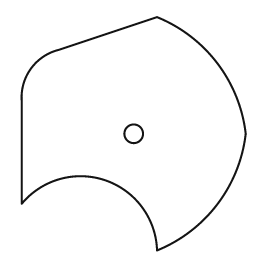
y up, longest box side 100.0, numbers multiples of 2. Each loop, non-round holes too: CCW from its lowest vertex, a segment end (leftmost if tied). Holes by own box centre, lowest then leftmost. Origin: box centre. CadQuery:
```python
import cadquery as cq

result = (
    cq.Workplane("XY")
    .moveTo(10.0, -50.0)
    .threePointArc((36.0, -30.0), (48.0, 0.0))
    .threePointArc((36.0, 30.0), (10.0, 50.0))
    .lineTo(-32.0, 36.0)
    .threePointArc((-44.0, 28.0), (-48.0, 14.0))
    .lineTo(-48.0, -30.0)
    .threePointArc((-12.0, -20.0), (10.0, -50.0))
    .close()
    .moveTo(0.0, 0.0)
    .circle(4.0)
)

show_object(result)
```